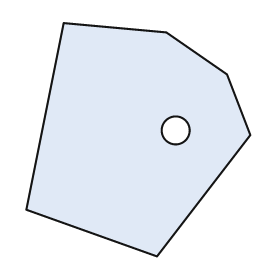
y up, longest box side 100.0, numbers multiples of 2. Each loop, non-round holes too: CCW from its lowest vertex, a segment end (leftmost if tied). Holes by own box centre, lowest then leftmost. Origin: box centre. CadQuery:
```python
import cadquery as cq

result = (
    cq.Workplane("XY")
    .moveTo(8.0, -50.0)
    .lineTo(48.0, 2.0)
    .lineTo(38.0, 28.0)
    .lineTo(12.0, 46.0)
    .lineTo(-32.0, 50.0)
    .lineTo(-48.0, -30.0)
    .close()
    .moveTo(16.0, 4.0)
    .circle(6.0)
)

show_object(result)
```